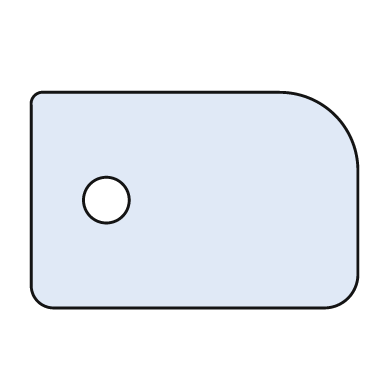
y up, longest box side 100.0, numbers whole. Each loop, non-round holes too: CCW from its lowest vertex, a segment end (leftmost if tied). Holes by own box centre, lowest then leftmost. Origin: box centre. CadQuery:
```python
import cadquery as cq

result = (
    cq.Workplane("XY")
    .moveTo(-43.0, -33.0)
    .lineTo(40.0, -33.0)
    .threePointArc((47.0, -30.0), (50.0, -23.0))
    .lineTo(50.0, 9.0)
    .threePointArc((43.0, 26.0), (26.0, 33.0))
    .lineTo(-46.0, 33.0)
    .threePointArc((-49.0, 32.0), (-50.0, 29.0))
    .lineTo(-50.0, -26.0)
    .threePointArc((-48.0, -31.0), (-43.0, -33.0))
    .close()
    .moveTo(-27.0, 0.0)
    .circle(7.0)
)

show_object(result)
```